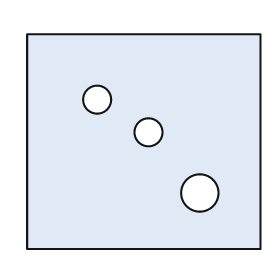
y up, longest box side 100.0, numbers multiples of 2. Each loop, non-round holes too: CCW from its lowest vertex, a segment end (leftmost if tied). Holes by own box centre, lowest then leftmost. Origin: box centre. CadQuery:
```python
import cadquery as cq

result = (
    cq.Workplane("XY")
    .moveTo(-50.0, -46.0)
    .lineTo(50.0, -46.0)
    .lineTo(50.0, 46.0)
    .lineTo(-50.0, 46.0)
    .close()
    .moveTo(24.0, -22.0)
    .circle(8.0)
    .moveTo(2.0, 4.0)
    .circle(6.0)
    .moveTo(-20.0, 18.0)
    .circle(6.0)
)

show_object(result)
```